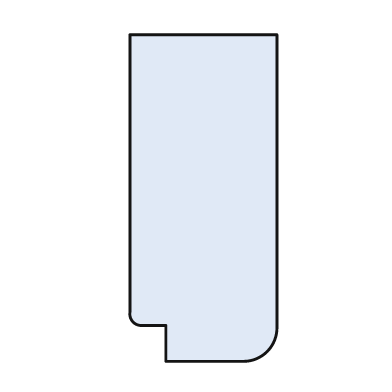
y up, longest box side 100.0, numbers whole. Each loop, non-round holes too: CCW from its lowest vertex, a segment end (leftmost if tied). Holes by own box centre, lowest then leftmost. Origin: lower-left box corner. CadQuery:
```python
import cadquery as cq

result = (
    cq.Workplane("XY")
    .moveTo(11.0, 0.0)
    .lineTo(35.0, 0.0)
    .threePointArc((42.0, 3.0), (45.0, 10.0))
    .lineTo(45.0, 100.0)
    .lineTo(0.0, 100.0)
    .lineTo(0.0, 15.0)
    .threePointArc((1.0, 12.0), (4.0, 11.0))
    .lineTo(11.0, 11.0)
    .close()
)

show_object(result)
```